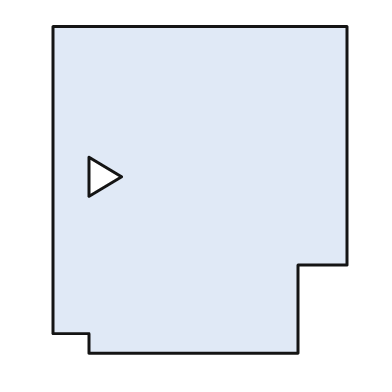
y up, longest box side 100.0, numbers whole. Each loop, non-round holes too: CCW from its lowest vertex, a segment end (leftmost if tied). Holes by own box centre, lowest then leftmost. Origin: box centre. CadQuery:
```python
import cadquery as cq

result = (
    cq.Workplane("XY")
    .moveTo(-34.0, -50.0)
    .lineTo(30.0, -50.0)
    .lineTo(30.0, -23.0)
    .lineTo(45.0, -23.0)
    .lineTo(45.0, 50.0)
    .lineTo(-45.0, 50.0)
    .lineTo(-45.0, -44.0)
    .lineTo(-34.0, -44.0)
    .close()
    .moveTo(-34.0, -2.0)
    .lineTo(-24.0, 4.0)
    .lineTo(-34.0, 10.0)
    .close()
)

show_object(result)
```